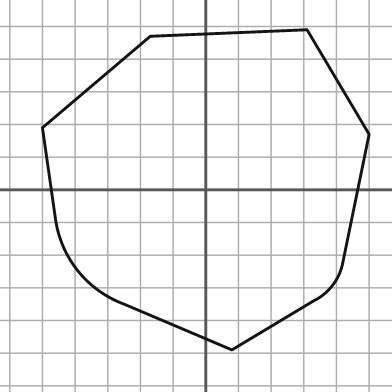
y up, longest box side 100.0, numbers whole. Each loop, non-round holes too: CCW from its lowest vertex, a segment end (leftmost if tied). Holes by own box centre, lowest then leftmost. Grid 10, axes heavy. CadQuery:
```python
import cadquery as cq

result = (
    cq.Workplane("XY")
    .moveTo(8.0, -49.0)
    .lineTo(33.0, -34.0)
    .threePointArc((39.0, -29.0), (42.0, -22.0))
    .lineTo(50.0, 17.0)
    .lineTo(31.0, 49.0)
    .lineTo(-17.0, 47.0)
    .lineTo(-50.0, 19.0)
    .lineTo(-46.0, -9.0)
    .threePointArc((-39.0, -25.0), (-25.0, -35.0))
    .close()
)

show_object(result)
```